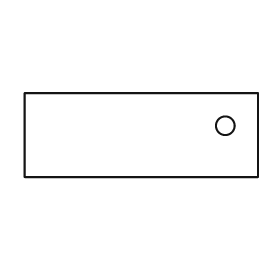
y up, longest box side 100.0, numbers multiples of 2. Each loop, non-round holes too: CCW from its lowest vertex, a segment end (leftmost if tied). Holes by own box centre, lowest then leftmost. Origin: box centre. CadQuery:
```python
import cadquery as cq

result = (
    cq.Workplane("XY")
    .moveTo(-50.0, -18.0)
    .lineTo(50.0, -18.0)
    .lineTo(50.0, 18.0)
    .lineTo(-50.0, 18.0)
    .close()
    .moveTo(36.0, 4.0)
    .circle(4.0)
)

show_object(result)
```